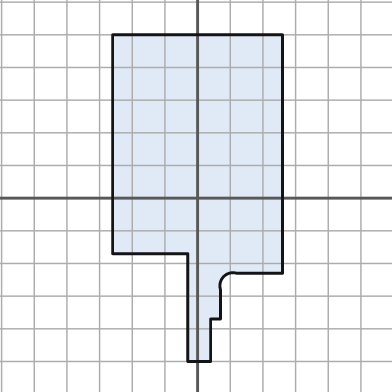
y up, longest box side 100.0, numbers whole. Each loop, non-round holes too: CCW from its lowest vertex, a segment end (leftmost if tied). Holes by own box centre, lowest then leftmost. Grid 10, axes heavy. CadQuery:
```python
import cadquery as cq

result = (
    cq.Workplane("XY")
    .moveTo(-3.0, -50.0)
    .lineTo(4.0, -50.0)
    .lineTo(4.0, -37.0)
    .lineTo(7.0, -37.0)
    .lineTo(7.0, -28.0)
    .threePointArc((8.0, -24.0), (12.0, -23.0))
    .lineTo(26.0, -23.0)
    .lineTo(26.0, 50.0)
    .lineTo(-26.0, 50.0)
    .lineTo(-26.0, -17.0)
    .lineTo(-3.0, -17.0)
    .close()
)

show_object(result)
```